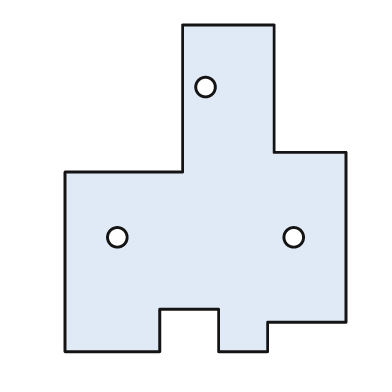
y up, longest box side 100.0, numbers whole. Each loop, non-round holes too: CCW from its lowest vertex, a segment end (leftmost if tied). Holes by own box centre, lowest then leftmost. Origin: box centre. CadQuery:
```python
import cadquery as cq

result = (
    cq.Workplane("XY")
    .moveTo(-43.0, -50.0)
    .lineTo(-14.0, -50.0)
    .lineTo(-14.0, -37.0)
    .lineTo(4.0, -37.0)
    .lineTo(4.0, -50.0)
    .lineTo(19.0, -50.0)
    .lineTo(19.0, -41.0)
    .lineTo(43.0, -41.0)
    .lineTo(43.0, 11.0)
    .lineTo(21.0, 11.0)
    .lineTo(21.0, 50.0)
    .lineTo(-7.0, 50.0)
    .lineTo(-7.0, 5.0)
    .lineTo(-43.0, 5.0)
    .close()
    .moveTo(-27.0, -15.0)
    .circle(3.0)
    .moveTo(27.0, -15.0)
    .circle(3.0)
    .moveTo(0.0, 31.0)
    .circle(3.0)
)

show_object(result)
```